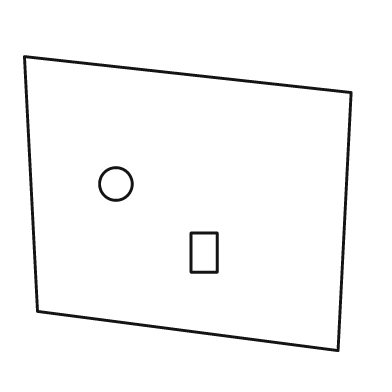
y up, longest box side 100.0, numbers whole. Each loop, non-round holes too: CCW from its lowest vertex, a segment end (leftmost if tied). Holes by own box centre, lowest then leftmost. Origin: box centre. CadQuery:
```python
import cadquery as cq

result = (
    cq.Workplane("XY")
    .moveTo(46.0, -45.0)
    .lineTo(50.0, 34.0)
    .lineTo(-50.0, 45.0)
    .lineTo(-46.0, -33.0)
    .close()
    .moveTo(1.0, -21.0)
    .lineTo(9.0, -21.0)
    .lineTo(9.0, -9.0)
    .lineTo(1.0, -9.0)
    .close()
    .moveTo(-22.0, 6.0)
    .circle(5.0)
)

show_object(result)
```